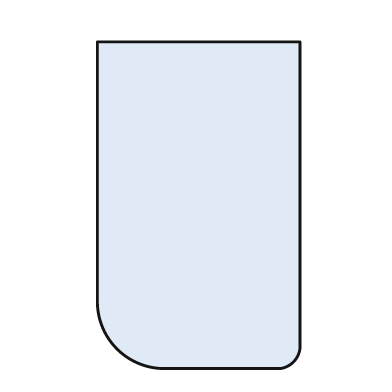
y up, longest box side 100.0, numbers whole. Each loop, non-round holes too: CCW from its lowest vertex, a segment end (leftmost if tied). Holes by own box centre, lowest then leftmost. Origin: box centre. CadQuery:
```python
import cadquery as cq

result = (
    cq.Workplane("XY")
    .moveTo(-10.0, -50.0)
    .lineTo(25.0, -50.0)
    .threePointArc((29.0, -48.0), (31.0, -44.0))
    .lineTo(31.0, 50.0)
    .lineTo(-31.0, 50.0)
    .lineTo(-31.0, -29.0)
    .threePointArc((-25.0, -44.0), (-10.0, -50.0))
    .close()
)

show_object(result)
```